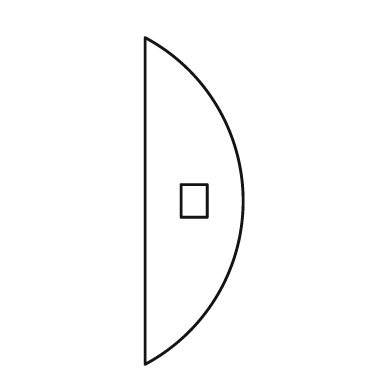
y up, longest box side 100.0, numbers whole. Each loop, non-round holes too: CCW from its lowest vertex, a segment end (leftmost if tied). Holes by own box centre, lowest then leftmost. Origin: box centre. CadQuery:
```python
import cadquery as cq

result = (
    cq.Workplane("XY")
    .moveTo(-15.0, -50.0)
    .threePointArc((15.0, 0.0), (-15.0, 50.0))
    .close()
    .moveTo(-4.0, -5.0)
    .lineTo(4.0, -5.0)
    .lineTo(4.0, 5.0)
    .lineTo(-4.0, 5.0)
    .close()
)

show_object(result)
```